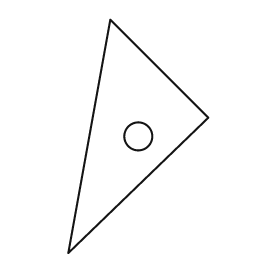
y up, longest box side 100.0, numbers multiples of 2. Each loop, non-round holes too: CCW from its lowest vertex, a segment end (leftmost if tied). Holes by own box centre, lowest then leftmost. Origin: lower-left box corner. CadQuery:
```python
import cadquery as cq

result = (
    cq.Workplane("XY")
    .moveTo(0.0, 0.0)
    .lineTo(60.0, 58.0)
    .lineTo(18.0, 100.0)
    .close()
    .moveTo(30.0, 50.0)
    .circle(6.0)
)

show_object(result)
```